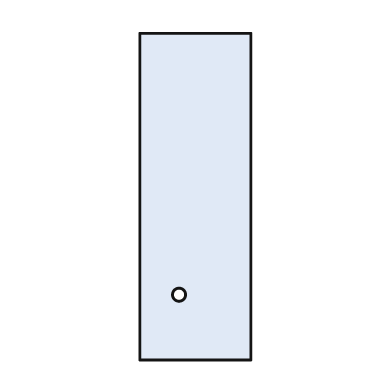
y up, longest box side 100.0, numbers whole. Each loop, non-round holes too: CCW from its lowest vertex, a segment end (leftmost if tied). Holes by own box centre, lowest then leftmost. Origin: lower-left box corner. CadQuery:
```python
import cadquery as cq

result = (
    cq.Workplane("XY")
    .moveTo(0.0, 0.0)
    .lineTo(34.0, 0.0)
    .lineTo(34.0, 100.0)
    .lineTo(0.0, 100.0)
    .close()
    .moveTo(12.0, 20.0)
    .circle(2.0)
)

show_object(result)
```